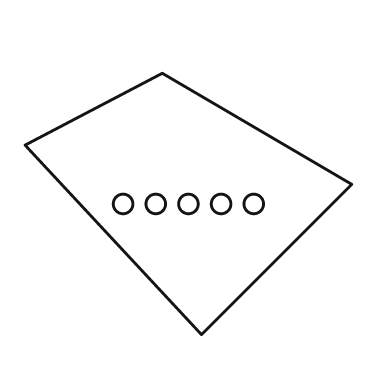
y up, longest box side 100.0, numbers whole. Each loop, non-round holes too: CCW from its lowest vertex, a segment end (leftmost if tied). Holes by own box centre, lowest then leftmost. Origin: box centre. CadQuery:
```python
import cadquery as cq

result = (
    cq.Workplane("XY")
    .moveTo(4.0, -40.0)
    .lineTo(50.0, 6.0)
    .lineTo(-8.0, 40.0)
    .lineTo(-50.0, 18.0)
    .close()
    .moveTo(-20.0, 0.0)
    .circle(3.0)
    .moveTo(-10.0, 0.0)
    .circle(3.0)
    .moveTo(0.0, 0.0)
    .circle(3.0)
    .moveTo(10.0, 0.0)
    .circle(3.0)
    .moveTo(20.0, 0.0)
    .circle(3.0)
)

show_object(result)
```